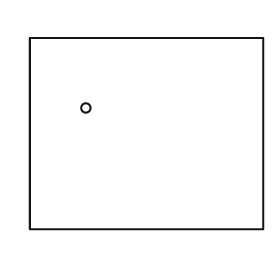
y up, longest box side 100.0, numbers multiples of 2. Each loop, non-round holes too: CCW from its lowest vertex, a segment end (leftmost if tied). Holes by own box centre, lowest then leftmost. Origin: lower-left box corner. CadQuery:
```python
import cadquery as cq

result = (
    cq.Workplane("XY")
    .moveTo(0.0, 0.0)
    .lineTo(100.0, 0.0)
    .lineTo(100.0, 82.0)
    .lineTo(0.0, 82.0)
    .close()
    .moveTo(24.0, 52.0)
    .circle(2.0)
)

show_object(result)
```